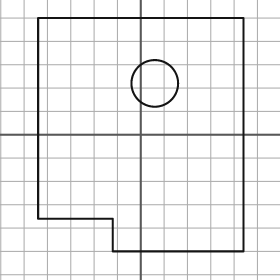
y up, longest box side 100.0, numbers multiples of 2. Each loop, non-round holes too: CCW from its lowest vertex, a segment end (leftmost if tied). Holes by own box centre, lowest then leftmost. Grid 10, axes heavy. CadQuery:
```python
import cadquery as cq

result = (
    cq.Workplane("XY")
    .moveTo(-12.0, -50.0)
    .lineTo(44.0, -50.0)
    .lineTo(44.0, 50.0)
    .lineTo(-44.0, 50.0)
    .lineTo(-44.0, -36.0)
    .lineTo(-12.0, -36.0)
    .close()
    .moveTo(6.0, 22.0)
    .circle(10.0)
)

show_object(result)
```